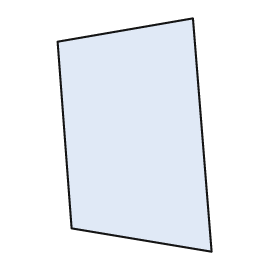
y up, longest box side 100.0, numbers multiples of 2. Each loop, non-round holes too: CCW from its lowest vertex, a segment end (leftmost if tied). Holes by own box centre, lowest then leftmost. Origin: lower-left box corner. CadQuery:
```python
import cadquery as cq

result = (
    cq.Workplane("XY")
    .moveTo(66.0, 0.0)
    .lineTo(58.0, 100.0)
    .lineTo(0.0, 90.0)
    .lineTo(6.0, 10.0)
    .close()
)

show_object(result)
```